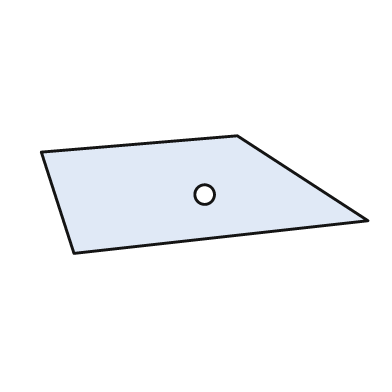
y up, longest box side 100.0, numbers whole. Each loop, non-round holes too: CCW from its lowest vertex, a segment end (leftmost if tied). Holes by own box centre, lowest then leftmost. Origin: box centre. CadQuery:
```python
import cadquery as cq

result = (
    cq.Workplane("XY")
    .moveTo(-40.0, -18.0)
    .lineTo(50.0, -8.0)
    .lineTo(10.0, 18.0)
    .lineTo(-50.0, 13.0)
    .close()
    .moveTo(0.0, 0.0)
    .circle(3.0)
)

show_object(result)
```